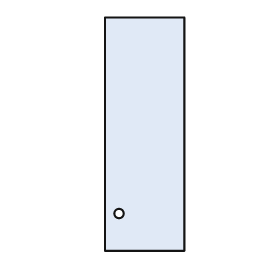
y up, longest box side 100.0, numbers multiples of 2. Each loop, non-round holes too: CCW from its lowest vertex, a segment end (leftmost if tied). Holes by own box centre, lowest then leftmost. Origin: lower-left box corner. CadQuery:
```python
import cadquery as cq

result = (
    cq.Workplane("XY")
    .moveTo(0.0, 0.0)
    .lineTo(34.0, 0.0)
    .lineTo(34.0, 100.0)
    .lineTo(0.0, 100.0)
    .close()
    .moveTo(6.0, 16.0)
    .circle(2.0)
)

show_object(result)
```